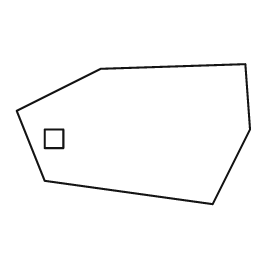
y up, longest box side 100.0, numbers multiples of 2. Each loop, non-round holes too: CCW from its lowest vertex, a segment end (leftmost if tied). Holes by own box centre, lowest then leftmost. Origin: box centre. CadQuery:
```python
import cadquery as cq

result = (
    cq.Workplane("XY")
    .moveTo(34.0, -30.0)
    .lineTo(50.0, 2.0)
    .lineTo(48.0, 30.0)
    .lineTo(-14.0, 28.0)
    .lineTo(-50.0, 10.0)
    .lineTo(-38.0, -20.0)
    .close()
    .moveTo(-38.0, -6.0)
    .lineTo(-30.0, -6.0)
    .lineTo(-30.0, 2.0)
    .lineTo(-38.0, 2.0)
    .close()
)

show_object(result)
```